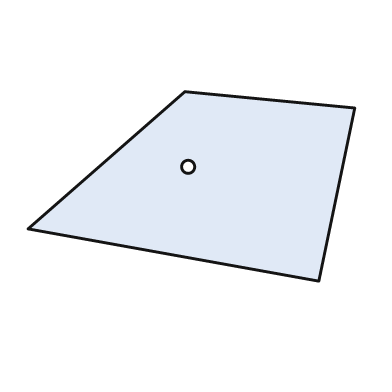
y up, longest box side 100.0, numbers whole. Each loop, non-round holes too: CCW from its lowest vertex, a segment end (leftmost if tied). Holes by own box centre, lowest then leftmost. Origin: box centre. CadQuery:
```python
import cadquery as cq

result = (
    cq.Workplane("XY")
    .moveTo(39.0, -29.0)
    .lineTo(50.0, 24.0)
    .lineTo(-2.0, 29.0)
    .lineTo(-50.0, -13.0)
    .close()
    .moveTo(-1.0, 6.0)
    .circle(2.0)
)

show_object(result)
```